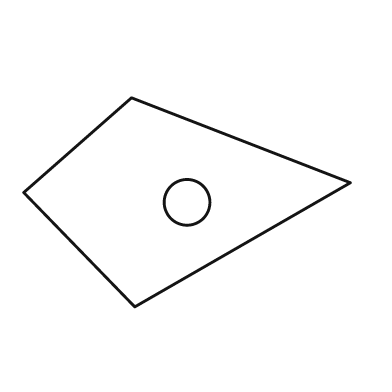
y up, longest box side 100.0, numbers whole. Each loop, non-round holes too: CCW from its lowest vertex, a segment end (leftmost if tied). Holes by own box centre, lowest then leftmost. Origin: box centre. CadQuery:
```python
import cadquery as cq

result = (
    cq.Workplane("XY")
    .moveTo(-16.0, -32.0)
    .lineTo(50.0, 6.0)
    .lineTo(-17.0, 32.0)
    .lineTo(-50.0, 3.0)
    .close()
    .moveTo(0.0, 0.0)
    .circle(7.0)
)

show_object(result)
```